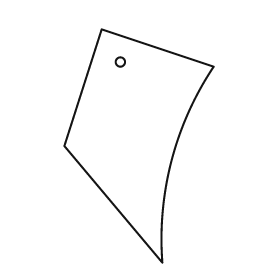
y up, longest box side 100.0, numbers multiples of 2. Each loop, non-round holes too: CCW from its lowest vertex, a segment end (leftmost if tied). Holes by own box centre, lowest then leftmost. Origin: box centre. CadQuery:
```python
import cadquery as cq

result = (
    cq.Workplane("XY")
    .moveTo(10.0, -50.0)
    .threePointArc((14.0, -6.0), (32.0, 34.0))
    .lineTo(-16.0, 50.0)
    .lineTo(-32.0, 0.0)
    .close()
    .moveTo(-8.0, 36.0)
    .circle(2.0)
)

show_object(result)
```